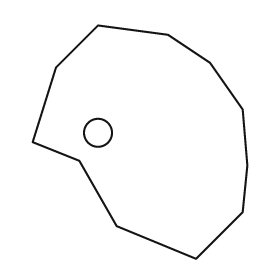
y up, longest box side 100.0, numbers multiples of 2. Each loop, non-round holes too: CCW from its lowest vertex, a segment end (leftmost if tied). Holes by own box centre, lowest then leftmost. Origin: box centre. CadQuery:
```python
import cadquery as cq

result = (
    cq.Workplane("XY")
    .moveTo(24.0, -50.0)
    .lineTo(44.0, -30.0)
    .lineTo(46.0, -10.0)
    .lineTo(44.0, 14.0)
    .lineTo(30.0, 34.0)
    .lineTo(12.0, 46.0)
    .lineTo(-18.0, 50.0)
    .lineTo(-36.0, 32.0)
    .lineTo(-46.0, 0.0)
    .lineTo(-26.0, -8.0)
    .lineTo(-10.0, -36.0)
    .close()
    .moveTo(-18.0, 4.0)
    .circle(6.0)
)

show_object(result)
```